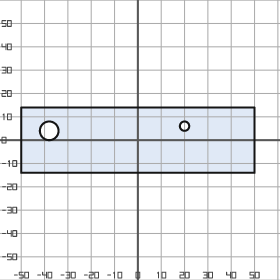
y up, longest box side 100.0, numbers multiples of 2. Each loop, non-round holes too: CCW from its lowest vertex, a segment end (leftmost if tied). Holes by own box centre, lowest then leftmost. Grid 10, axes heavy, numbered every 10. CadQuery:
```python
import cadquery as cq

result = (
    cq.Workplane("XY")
    .moveTo(-50.0, -14.0)
    .lineTo(50.0, -14.0)
    .lineTo(50.0, 14.0)
    .lineTo(-50.0, 14.0)
    .close()
    .moveTo(-38.0, 4.0)
    .circle(4.0)
    .moveTo(20.0, 6.0)
    .circle(2.0)
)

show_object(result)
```